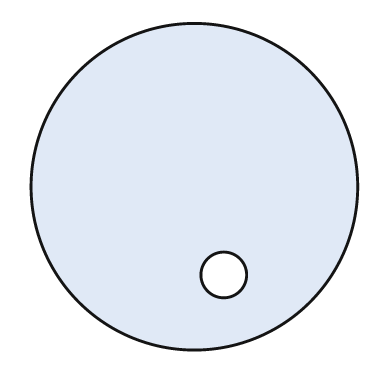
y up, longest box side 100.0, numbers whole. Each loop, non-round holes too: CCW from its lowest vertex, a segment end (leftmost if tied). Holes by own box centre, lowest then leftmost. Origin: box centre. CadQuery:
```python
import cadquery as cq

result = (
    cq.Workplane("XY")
    .moveTo(0.0, 0.0)
    .circle(50.0)
    .moveTo(9.0, -27.0)
    .circle(7.0)
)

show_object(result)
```